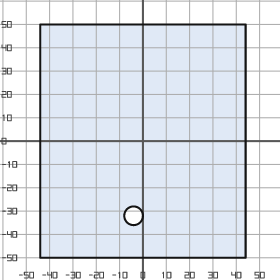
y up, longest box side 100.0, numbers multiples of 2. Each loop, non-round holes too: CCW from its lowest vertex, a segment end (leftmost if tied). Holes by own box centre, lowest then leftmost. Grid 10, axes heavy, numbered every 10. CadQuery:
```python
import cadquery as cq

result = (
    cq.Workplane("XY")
    .moveTo(-44.0, -50.0)
    .lineTo(44.0, -50.0)
    .lineTo(44.0, 50.0)
    .lineTo(-44.0, 50.0)
    .close()
    .moveTo(-4.0, -32.0)
    .circle(4.0)
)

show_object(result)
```